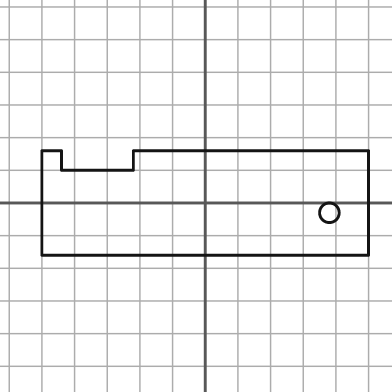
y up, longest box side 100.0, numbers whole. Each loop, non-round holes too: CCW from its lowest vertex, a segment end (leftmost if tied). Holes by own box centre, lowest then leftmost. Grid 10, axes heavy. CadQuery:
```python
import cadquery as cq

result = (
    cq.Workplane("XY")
    .moveTo(-50.0, -16.0)
    .lineTo(50.0, -16.0)
    .lineTo(50.0, 16.0)
    .lineTo(-22.0, 16.0)
    .lineTo(-22.0, 10.0)
    .lineTo(-44.0, 10.0)
    .lineTo(-44.0, 16.0)
    .lineTo(-50.0, 16.0)
    .close()
    .moveTo(38.0, -3.0)
    .circle(3.0)
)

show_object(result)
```